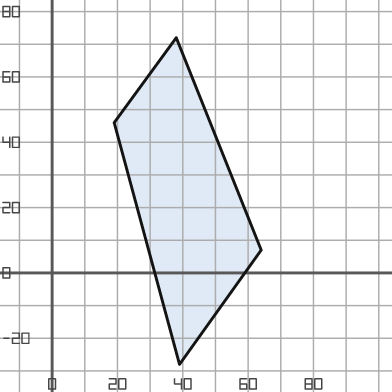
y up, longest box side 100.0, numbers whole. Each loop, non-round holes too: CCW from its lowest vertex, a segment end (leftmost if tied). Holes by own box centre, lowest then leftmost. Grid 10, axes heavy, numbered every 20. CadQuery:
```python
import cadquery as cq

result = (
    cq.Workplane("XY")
    .moveTo(39.0, -28.0)
    .lineTo(64.0, 7.0)
    .lineTo(38.0, 72.0)
    .lineTo(19.0, 46.0)
    .close()
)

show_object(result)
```